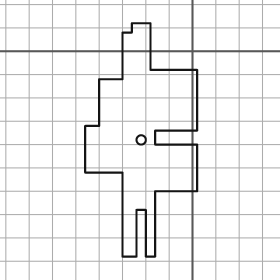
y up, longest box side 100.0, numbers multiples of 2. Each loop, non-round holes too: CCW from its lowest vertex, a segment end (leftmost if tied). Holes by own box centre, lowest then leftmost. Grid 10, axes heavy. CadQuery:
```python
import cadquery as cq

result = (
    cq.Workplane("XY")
    .moveTo(-30.0, -88.0)
    .lineTo(-24.0, -88.0)
    .lineTo(-24.0, -68.0)
    .lineTo(-20.0, -68.0)
    .lineTo(-20.0, -88.0)
    .lineTo(-16.0, -88.0)
    .lineTo(-16.0, -60.0)
    .lineTo(2.0, -60.0)
    .lineTo(2.0, -40.0)
    .lineTo(-16.0, -40.0)
    .lineTo(-16.0, -34.0)
    .lineTo(2.0, -34.0)
    .lineTo(2.0, -8.0)
    .lineTo(-18.0, -8.0)
    .lineTo(-18.0, 12.0)
    .lineTo(-26.0, 12.0)
    .lineTo(-26.0, 8.0)
    .lineTo(-30.0, 8.0)
    .lineTo(-30.0, -12.0)
    .lineTo(-40.0, -12.0)
    .lineTo(-40.0, -32.0)
    .lineTo(-46.0, -32.0)
    .lineTo(-46.0, -52.0)
    .lineTo(-30.0, -52.0)
    .close()
    .moveTo(-22.0, -38.0)
    .circle(2.0)
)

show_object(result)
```